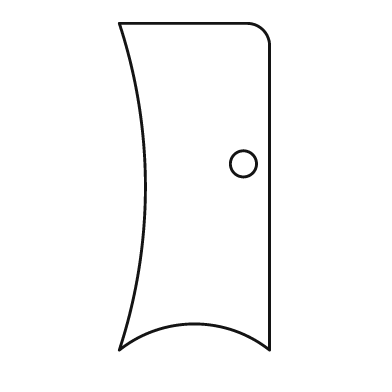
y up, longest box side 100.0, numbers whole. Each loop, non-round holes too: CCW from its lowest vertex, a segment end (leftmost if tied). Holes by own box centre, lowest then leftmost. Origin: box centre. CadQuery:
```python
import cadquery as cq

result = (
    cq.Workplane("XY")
    .moveTo(-23.0, -50.0)
    .threePointArc((0.0, -42.0), (23.0, -50.0))
    .lineTo(23.0, 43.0)
    .threePointArc((21.0, 48.0), (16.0, 50.0))
    .lineTo(-23.0, 50.0)
    .threePointArc((-15.0, 0.0), (-23.0, -50.0))
    .close()
    .moveTo(15.0, 7.0)
    .circle(4.0)
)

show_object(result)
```